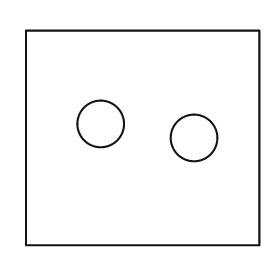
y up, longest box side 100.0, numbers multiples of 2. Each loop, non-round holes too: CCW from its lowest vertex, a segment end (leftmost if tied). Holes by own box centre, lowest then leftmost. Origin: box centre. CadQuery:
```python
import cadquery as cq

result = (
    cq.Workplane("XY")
    .moveTo(-50.0, -46.0)
    .lineTo(50.0, -46.0)
    .lineTo(50.0, 46.0)
    .lineTo(-50.0, 46.0)
    .close()
    .moveTo(22.0, 0.0)
    .circle(10.0)
    .moveTo(-18.0, 6.0)
    .circle(10.0)
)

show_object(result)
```